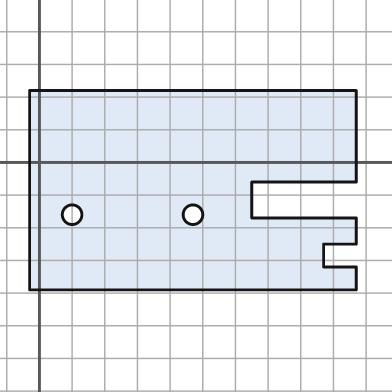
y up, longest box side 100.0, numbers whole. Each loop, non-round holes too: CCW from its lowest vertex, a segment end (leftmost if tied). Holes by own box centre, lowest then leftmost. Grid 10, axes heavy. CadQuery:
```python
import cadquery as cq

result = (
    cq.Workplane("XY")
    .moveTo(-3.0, -39.0)
    .lineTo(97.0, -39.0)
    .lineTo(97.0, -32.0)
    .lineTo(87.0, -32.0)
    .lineTo(87.0, -25.0)
    .lineTo(97.0, -25.0)
    .lineTo(97.0, -17.0)
    .lineTo(65.0, -17.0)
    .lineTo(65.0, -6.0)
    .lineTo(97.0, -6.0)
    .lineTo(97.0, 22.0)
    .lineTo(-3.0, 22.0)
    .close()
    .moveTo(10.0, -16.0)
    .circle(3.0)
    .moveTo(47.0, -16.0)
    .circle(3.0)
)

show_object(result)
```